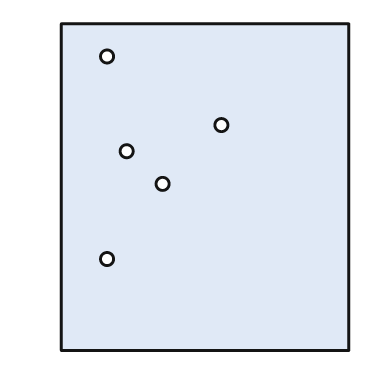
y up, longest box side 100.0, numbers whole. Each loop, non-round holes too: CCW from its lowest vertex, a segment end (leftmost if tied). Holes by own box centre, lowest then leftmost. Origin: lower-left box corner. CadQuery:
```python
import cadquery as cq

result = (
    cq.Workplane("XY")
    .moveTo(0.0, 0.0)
    .lineTo(88.0, 0.0)
    .lineTo(88.0, 100.0)
    .lineTo(0.0, 100.0)
    .close()
    .moveTo(14.0, 28.0)
    .circle(2.0)
    .moveTo(31.0, 51.0)
    .circle(2.0)
    .moveTo(20.0, 61.0)
    .circle(2.0)
    .moveTo(49.0, 69.0)
    .circle(2.0)
    .moveTo(14.0, 90.0)
    .circle(2.0)
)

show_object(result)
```